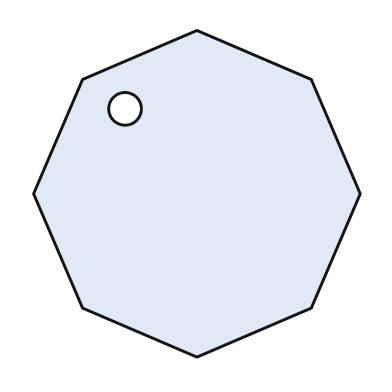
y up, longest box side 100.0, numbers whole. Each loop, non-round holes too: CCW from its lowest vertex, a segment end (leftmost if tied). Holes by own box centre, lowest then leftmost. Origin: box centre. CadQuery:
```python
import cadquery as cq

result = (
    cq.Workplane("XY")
    .moveTo(0.0, -50.0)
    .lineTo(35.0, -35.0)
    .lineTo(50.0, 0.0)
    .lineTo(35.0, 35.0)
    .lineTo(0.0, 50.0)
    .lineTo(-35.0, 35.0)
    .lineTo(-50.0, 0.0)
    .lineTo(-35.0, -35.0)
    .close()
    .moveTo(-22.0, 26.0)
    .circle(5.0)
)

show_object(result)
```